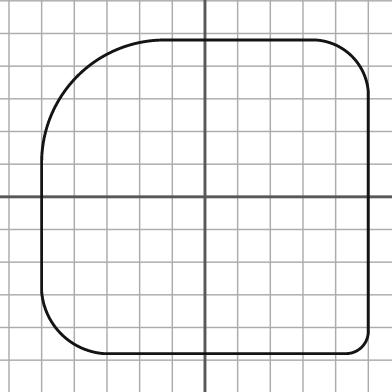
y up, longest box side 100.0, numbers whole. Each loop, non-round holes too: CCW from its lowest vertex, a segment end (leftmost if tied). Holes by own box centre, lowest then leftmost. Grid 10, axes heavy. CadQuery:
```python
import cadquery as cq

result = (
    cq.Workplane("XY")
    .moveTo(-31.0, -48.0)
    .lineTo(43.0, -48.0)
    .threePointArc((48.0, -46.0), (50.0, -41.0))
    .lineTo(50.0, 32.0)
    .threePointArc((45.0, 43.0), (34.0, 48.0))
    .lineTo(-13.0, 48.0)
    .threePointArc((-39.0, 37.0), (-50.0, 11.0))
    .lineTo(-50.0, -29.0)
    .threePointArc((-44.0, -42.0), (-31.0, -48.0))
    .close()
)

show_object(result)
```